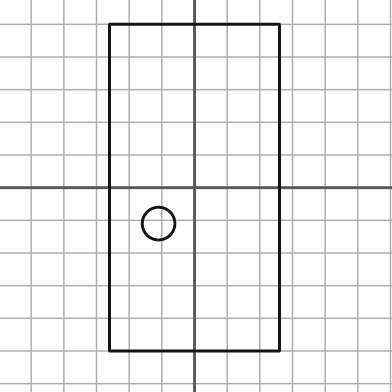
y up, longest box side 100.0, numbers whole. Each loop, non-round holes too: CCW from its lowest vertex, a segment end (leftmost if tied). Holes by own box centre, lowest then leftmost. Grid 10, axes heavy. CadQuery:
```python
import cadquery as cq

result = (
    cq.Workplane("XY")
    .moveTo(-26.0, -50.0)
    .lineTo(26.0, -50.0)
    .lineTo(26.0, 50.0)
    .lineTo(-26.0, 50.0)
    .close()
    .moveTo(-11.0, -11.0)
    .circle(5.0)
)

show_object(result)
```